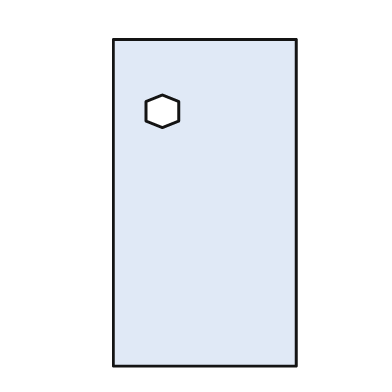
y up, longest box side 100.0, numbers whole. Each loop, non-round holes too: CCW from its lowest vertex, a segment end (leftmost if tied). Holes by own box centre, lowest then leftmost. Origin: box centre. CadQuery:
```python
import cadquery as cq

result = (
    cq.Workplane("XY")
    .moveTo(-28.0, -50.0)
    .lineTo(28.0, -50.0)
    .lineTo(28.0, 50.0)
    .lineTo(-28.0, 50.0)
    .close()
    .moveTo(-13.0, 23.0)
    .lineTo(-8.0, 25.0)
    .lineTo(-8.0, 31.0)
    .lineTo(-13.0, 33.0)
    .lineTo(-18.0, 31.0)
    .lineTo(-18.0, 25.0)
    .close()
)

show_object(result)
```